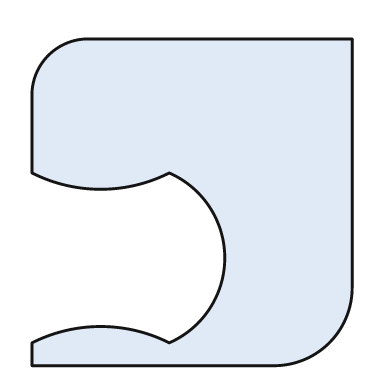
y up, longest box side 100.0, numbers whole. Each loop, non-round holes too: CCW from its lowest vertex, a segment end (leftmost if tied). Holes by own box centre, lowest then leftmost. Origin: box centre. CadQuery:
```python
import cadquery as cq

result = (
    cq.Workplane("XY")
    .moveTo(-49.0, -50.0)
    .lineTo(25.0, -50.0)
    .threePointArc((42.0, -43.0), (49.0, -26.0))
    .lineTo(49.0, 50.0)
    .lineTo(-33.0, 50.0)
    .threePointArc((-44.0, 45.0), (-49.0, 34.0))
    .lineTo(-49.0, 9.0)
    .threePointArc((-28.0, 4.0), (-7.0, 9.0))
    .threePointArc((10.0, -17.0), (-7.0, -43.0))
    .threePointArc((-28.0, -38.0), (-49.0, -43.0))
    .close()
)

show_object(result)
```